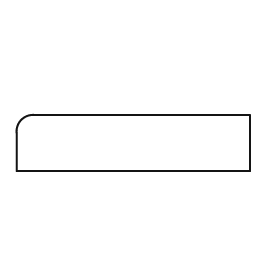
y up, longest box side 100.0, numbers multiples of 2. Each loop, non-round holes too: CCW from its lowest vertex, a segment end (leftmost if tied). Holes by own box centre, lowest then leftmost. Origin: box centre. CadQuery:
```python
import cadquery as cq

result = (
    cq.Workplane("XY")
    .moveTo(-50.0, -12.0)
    .lineTo(50.0, -12.0)
    .lineTo(50.0, 12.0)
    .lineTo(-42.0, 12.0)
    .threePointArc((-48.0, 10.0), (-50.0, 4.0))
    .close()
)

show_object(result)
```